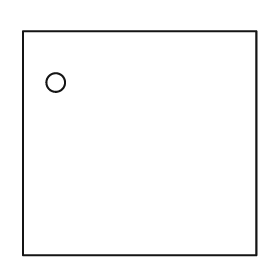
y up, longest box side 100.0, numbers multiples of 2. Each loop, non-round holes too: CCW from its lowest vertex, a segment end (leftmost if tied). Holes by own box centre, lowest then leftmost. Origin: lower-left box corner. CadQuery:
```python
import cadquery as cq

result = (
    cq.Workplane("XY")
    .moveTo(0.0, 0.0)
    .lineTo(100.0, 0.0)
    .lineTo(100.0, 96.0)
    .lineTo(0.0, 96.0)
    .close()
    .moveTo(14.0, 74.0)
    .circle(4.0)
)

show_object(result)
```